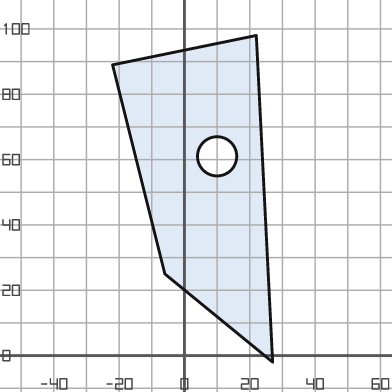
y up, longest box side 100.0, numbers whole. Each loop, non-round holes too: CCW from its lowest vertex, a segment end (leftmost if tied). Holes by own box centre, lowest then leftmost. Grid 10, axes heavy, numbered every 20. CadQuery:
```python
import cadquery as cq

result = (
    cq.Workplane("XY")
    .moveTo(27.0, -2.0)
    .lineTo(22.0, 98.0)
    .lineTo(-22.0, 89.0)
    .lineTo(-6.0, 25.0)
    .close()
    .moveTo(10.0, 61.0)
    .circle(6.0)
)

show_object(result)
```